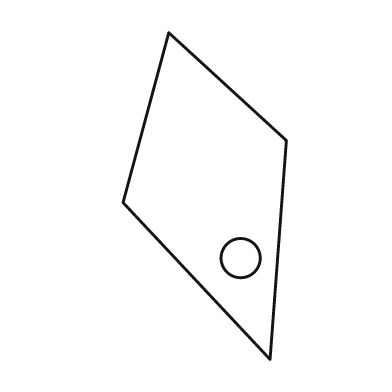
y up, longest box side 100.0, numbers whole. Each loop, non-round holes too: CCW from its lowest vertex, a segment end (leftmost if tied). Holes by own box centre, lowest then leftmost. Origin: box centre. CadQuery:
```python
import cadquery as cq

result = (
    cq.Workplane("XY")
    .moveTo(20.0, -50.0)
    .lineTo(25.0, 17.0)
    .lineTo(-11.0, 50.0)
    .lineTo(-25.0, -2.0)
    .close()
    .moveTo(11.0, -19.0)
    .circle(6.0)
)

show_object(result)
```